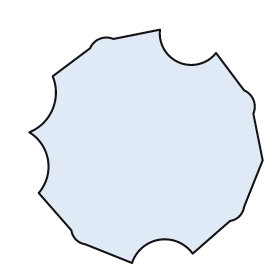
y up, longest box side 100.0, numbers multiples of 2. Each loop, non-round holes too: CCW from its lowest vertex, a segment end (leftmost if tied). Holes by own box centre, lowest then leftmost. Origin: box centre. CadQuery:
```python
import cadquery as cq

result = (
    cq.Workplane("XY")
    .moveTo(-6.0, -50.0)
    .threePointArc((6.0, -40.0), (20.0, -46.0))
    .lineTo(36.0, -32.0)
    .threePointArc((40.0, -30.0), (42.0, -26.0))
    .lineTo(50.0, -6.0)
    .lineTo(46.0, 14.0)
    .threePointArc((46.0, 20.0), (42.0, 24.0))
    .lineTo(30.0, 40.0)
    .threePointArc((14.0, 36.0), (6.0, 50.0))
    .lineTo(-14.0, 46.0)
    .threePointArc((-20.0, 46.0), (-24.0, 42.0))
    .lineTo(-40.0, 30.0)
    .threePointArc((-40.0, 16.0), (-50.0, 6.0))
    .threePointArc((-42.0, -6.0), (-46.0, -20.0))
    .lineTo(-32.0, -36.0)
    .threePointArc((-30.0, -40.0), (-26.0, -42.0))
    .close()
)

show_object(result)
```